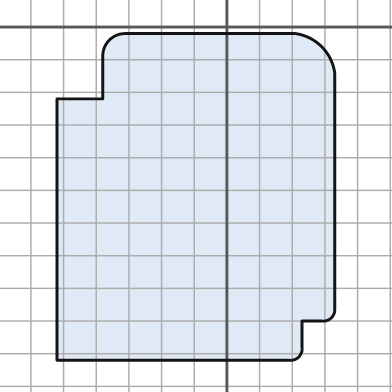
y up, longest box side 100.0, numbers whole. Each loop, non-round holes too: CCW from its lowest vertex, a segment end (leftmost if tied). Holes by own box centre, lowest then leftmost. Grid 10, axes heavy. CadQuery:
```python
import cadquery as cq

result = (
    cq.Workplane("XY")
    .moveTo(-52.0, -102.0)
    .lineTo(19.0, -102.0)
    .threePointArc((22.0, -101.0), (23.0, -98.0))
    .lineTo(23.0, -90.0)
    .lineTo(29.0, -90.0)
    .threePointArc((32.0, -89.0), (33.0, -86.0))
    .lineTo(33.0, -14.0)
    .threePointArc((29.0, -6.0), (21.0, -2.0))
    .lineTo(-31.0, -2.0)
    .threePointArc((-36.0, -4.0), (-38.0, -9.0))
    .lineTo(-38.0, -22.0)
    .lineTo(-52.0, -22.0)
    .close()
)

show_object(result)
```